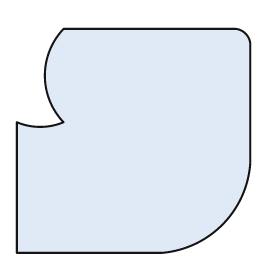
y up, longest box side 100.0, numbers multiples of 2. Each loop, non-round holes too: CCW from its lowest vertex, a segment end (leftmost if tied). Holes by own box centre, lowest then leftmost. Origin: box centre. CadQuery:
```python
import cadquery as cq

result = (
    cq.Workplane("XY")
    .moveTo(-50.0, -48.0)
    .lineTo(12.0, -48.0)
    .threePointArc((38.0, -36.0), (50.0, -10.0))
    .lineTo(50.0, 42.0)
    .threePointArc((48.0, 46.0), (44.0, 48.0))
    .lineTo(-30.0, 48.0)
    .threePointArc((-38.0, 28.0), (-30.0, 8.0))
    .threePointArc((-40.0, 6.0), (-50.0, 8.0))
    .close()
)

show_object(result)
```